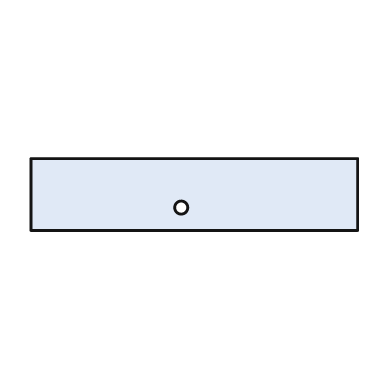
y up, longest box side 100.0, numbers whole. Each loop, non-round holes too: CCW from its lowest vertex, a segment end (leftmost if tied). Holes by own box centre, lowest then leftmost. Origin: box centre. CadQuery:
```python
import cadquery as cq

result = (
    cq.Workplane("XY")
    .moveTo(-50.0, -11.0)
    .lineTo(50.0, -11.0)
    .lineTo(50.0, 11.0)
    .lineTo(-50.0, 11.0)
    .close()
    .moveTo(-4.0, -4.0)
    .circle(2.0)
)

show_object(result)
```